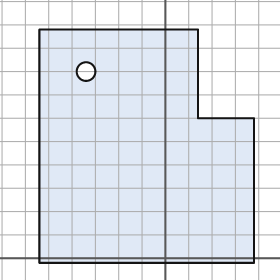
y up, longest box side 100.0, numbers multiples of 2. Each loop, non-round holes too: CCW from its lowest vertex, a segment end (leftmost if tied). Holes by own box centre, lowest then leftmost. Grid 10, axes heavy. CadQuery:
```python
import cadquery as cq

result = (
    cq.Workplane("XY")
    .moveTo(-54.0, -2.0)
    .lineTo(38.0, -2.0)
    .lineTo(38.0, 60.0)
    .lineTo(14.0, 60.0)
    .lineTo(14.0, 98.0)
    .lineTo(-54.0, 98.0)
    .close()
    .moveTo(-34.0, 80.0)
    .circle(4.0)
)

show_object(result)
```